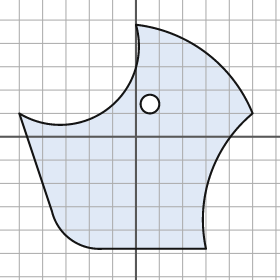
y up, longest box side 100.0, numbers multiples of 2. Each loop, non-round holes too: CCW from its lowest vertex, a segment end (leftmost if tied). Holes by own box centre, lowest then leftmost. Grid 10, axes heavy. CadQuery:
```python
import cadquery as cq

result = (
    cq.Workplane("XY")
    .moveTo(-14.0, -48.0)
    .lineTo(30.0, -48.0)
    .threePointArc((32.0, -16.0), (50.0, 10.0))
    .threePointArc((30.0, 36.0), (0.0, 48.0))
    .threePointArc((-12.0, 12.0), (-50.0, 10.0))
    .lineTo(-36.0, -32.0)
    .threePointArc((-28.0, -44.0), (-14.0, -48.0))
    .close()
    .moveTo(6.0, 14.0)
    .circle(4.0)
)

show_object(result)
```